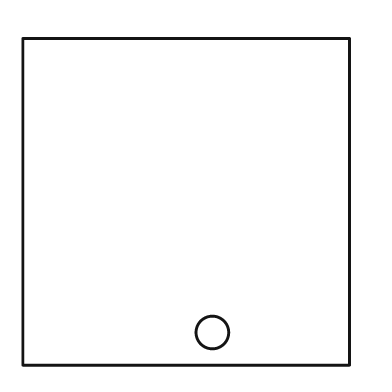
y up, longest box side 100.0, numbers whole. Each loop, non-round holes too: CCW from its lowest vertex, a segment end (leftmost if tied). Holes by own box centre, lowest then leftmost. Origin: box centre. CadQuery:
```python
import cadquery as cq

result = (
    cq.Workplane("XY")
    .moveTo(-50.0, -50.0)
    .lineTo(50.0, -50.0)
    .lineTo(50.0, 50.0)
    .lineTo(-50.0, 50.0)
    .close()
    .moveTo(8.0, -40.0)
    .circle(5.0)
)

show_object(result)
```